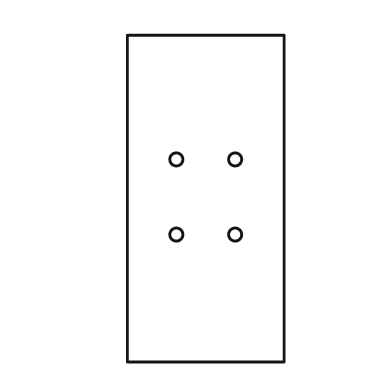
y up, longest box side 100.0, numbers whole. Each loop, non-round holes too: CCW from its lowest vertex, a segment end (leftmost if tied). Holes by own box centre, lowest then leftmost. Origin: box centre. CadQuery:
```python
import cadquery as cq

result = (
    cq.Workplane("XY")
    .moveTo(-24.0, -50.0)
    .lineTo(24.0, -50.0)
    .lineTo(24.0, 50.0)
    .lineTo(-24.0, 50.0)
    .close()
    .moveTo(-9.0, -11.0)
    .circle(2.0)
    .moveTo(9.0, -11.0)
    .circle(2.0)
    .moveTo(-9.0, 12.0)
    .circle(2.0)
    .moveTo(9.0, 12.0)
    .circle(2.0)
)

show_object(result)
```